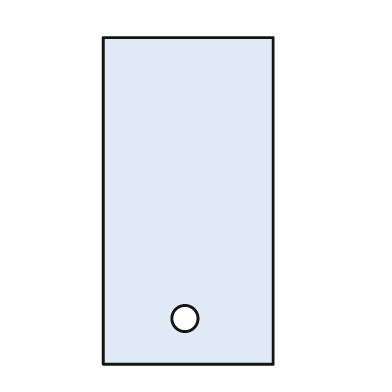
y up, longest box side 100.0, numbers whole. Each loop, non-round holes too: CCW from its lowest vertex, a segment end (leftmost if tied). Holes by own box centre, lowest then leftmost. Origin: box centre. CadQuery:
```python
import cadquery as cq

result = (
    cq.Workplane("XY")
    .moveTo(-26.0, -50.0)
    .lineTo(26.0, -50.0)
    .lineTo(26.0, 50.0)
    .lineTo(-26.0, 50.0)
    .close()
    .moveTo(-1.0, -36.0)
    .circle(4.0)
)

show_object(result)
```